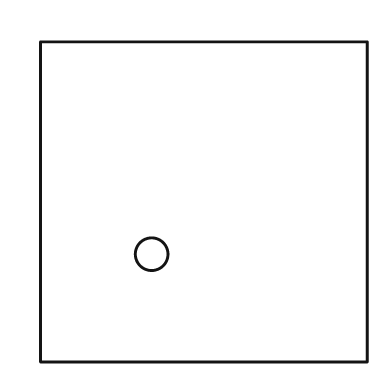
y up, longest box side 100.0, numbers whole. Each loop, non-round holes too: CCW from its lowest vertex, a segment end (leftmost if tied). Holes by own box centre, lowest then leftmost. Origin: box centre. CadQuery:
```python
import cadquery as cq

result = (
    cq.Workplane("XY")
    .moveTo(-50.0, -49.0)
    .lineTo(50.0, -49.0)
    .lineTo(50.0, 49.0)
    .lineTo(-50.0, 49.0)
    .close()
    .moveTo(-16.0, -16.0)
    .circle(5.0)
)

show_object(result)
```